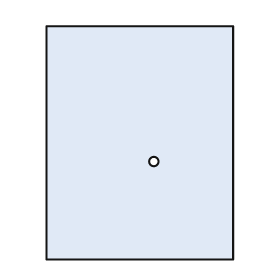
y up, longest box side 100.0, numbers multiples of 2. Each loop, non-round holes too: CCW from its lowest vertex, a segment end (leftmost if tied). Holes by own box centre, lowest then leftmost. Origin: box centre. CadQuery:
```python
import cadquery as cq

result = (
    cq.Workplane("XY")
    .moveTo(-40.0, -50.0)
    .lineTo(40.0, -50.0)
    .lineTo(40.0, 50.0)
    .lineTo(-40.0, 50.0)
    .close()
    .moveTo(6.0, -8.0)
    .circle(2.0)
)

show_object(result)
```